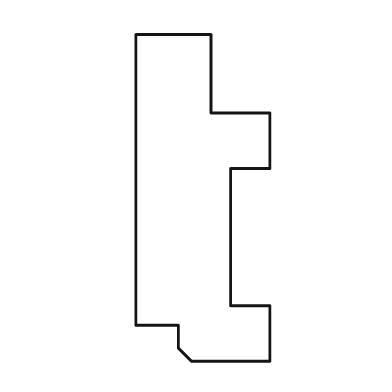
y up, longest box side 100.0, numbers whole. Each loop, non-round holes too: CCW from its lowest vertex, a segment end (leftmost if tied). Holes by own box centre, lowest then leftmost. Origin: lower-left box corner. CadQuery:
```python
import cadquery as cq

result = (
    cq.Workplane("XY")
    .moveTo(17.0, 0.0)
    .lineTo(41.0, 0.0)
    .lineTo(41.0, 17.0)
    .lineTo(29.0, 17.0)
    .lineTo(29.0, 59.0)
    .lineTo(41.0, 59.0)
    .lineTo(41.0, 76.0)
    .lineTo(23.0, 76.0)
    .lineTo(23.0, 100.0)
    .lineTo(0.0, 100.0)
    .lineTo(0.0, 11.0)
    .lineTo(13.0, 11.0)
    .lineTo(13.0, 4.0)
    .close()
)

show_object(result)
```